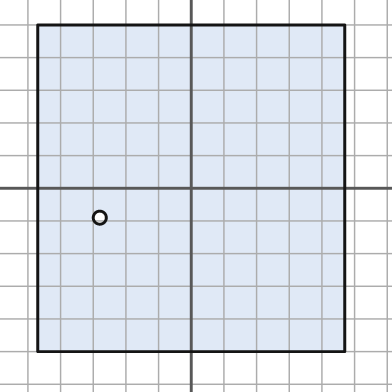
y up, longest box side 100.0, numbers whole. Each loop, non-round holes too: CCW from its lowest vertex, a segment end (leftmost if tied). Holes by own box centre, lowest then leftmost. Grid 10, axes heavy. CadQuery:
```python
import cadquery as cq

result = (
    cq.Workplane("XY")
    .moveTo(-47.0, -50.0)
    .lineTo(47.0, -50.0)
    .lineTo(47.0, 50.0)
    .lineTo(-47.0, 50.0)
    .close()
    .moveTo(-28.0, -9.0)
    .circle(2.0)
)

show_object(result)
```